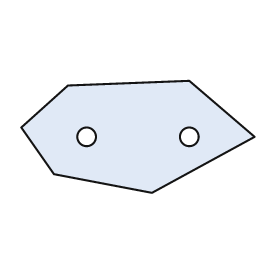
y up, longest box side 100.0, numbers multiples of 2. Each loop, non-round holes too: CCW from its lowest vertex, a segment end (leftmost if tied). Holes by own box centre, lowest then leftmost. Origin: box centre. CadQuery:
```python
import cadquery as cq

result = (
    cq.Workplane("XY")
    .moveTo(6.0, -24.0)
    .lineTo(50.0, 0.0)
    .lineTo(22.0, 24.0)
    .lineTo(-30.0, 22.0)
    .lineTo(-50.0, 4.0)
    .lineTo(-36.0, -16.0)
    .close()
    .moveTo(-22.0, 0.0)
    .circle(4.0)
    .moveTo(22.0, 0.0)
    .circle(4.0)
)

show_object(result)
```